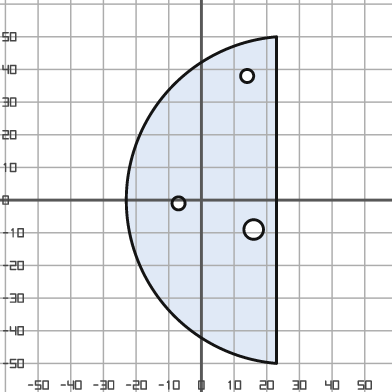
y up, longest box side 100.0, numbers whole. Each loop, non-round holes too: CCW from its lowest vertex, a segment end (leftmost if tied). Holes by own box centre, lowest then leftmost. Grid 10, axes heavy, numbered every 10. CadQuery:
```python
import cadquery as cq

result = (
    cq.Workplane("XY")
    .moveTo(23.0, -50.0)
    .lineTo(23.0, 50.0)
    .threePointArc((-23.0, 0.0), (23.0, -50.0))
    .close()
    .moveTo(16.0, -9.0)
    .circle(3.0)
    .moveTo(-7.0, -1.0)
    .circle(2.0)
    .moveTo(14.0, 38.0)
    .circle(2.0)
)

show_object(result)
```